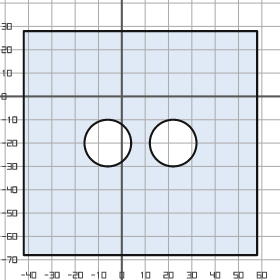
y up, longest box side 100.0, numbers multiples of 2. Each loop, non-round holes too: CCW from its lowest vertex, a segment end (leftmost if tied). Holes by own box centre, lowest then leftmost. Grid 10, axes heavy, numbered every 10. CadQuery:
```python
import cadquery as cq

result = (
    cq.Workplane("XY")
    .moveTo(-42.0, -68.0)
    .lineTo(58.0, -68.0)
    .lineTo(58.0, 28.0)
    .lineTo(-42.0, 28.0)
    .close()
    .moveTo(-6.0, -20.0)
    .circle(10.0)
    .moveTo(22.0, -20.0)
    .circle(10.0)
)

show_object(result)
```